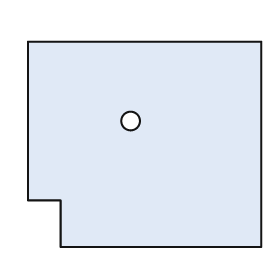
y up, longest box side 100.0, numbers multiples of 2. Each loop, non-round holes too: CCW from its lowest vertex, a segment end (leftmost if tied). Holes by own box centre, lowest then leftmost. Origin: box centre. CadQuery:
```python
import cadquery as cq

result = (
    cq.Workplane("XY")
    .moveTo(-36.0, -44.0)
    .lineTo(50.0, -44.0)
    .lineTo(50.0, 44.0)
    .lineTo(-50.0, 44.0)
    .lineTo(-50.0, -24.0)
    .lineTo(-36.0, -24.0)
    .close()
    .moveTo(-6.0, 10.0)
    .circle(4.0)
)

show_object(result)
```